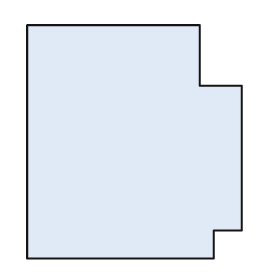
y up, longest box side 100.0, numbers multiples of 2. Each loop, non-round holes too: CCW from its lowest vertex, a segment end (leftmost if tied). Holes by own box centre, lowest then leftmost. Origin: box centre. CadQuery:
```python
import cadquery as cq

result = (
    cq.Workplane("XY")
    .moveTo(-46.0, -50.0)
    .lineTo(34.0, -50.0)
    .lineTo(34.0, -38.0)
    .lineTo(46.0, -38.0)
    .lineTo(46.0, 24.0)
    .lineTo(28.0, 24.0)
    .lineTo(28.0, 50.0)
    .lineTo(-46.0, 50.0)
    .close()
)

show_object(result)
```